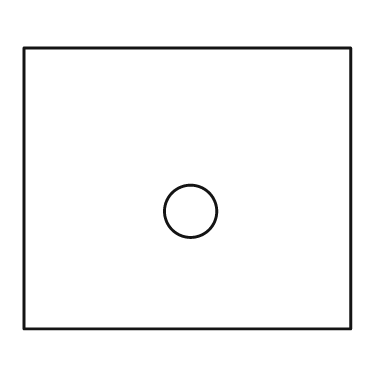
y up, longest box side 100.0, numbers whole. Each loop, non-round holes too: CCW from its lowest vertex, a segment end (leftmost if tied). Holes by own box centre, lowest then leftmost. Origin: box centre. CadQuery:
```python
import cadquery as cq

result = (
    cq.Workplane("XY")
    .moveTo(-50.0, -43.0)
    .lineTo(50.0, -43.0)
    .lineTo(50.0, 43.0)
    .lineTo(-50.0, 43.0)
    .close()
    .moveTo(1.0, -7.0)
    .circle(8.0)
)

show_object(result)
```